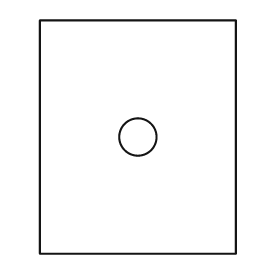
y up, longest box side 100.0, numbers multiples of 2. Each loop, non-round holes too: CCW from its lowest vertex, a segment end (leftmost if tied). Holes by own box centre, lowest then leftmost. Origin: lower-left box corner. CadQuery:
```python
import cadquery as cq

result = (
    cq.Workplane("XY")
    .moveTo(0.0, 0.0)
    .lineTo(84.0, 0.0)
    .lineTo(84.0, 100.0)
    .lineTo(0.0, 100.0)
    .close()
    .moveTo(42.0, 50.0)
    .circle(8.0)
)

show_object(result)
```